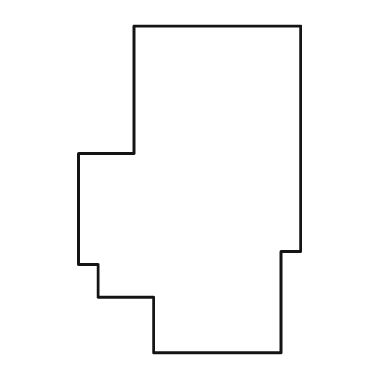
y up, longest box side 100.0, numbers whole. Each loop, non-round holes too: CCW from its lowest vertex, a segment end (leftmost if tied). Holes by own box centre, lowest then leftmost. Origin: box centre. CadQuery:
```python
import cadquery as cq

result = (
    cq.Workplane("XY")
    .moveTo(-11.0, -50.0)
    .lineTo(28.0, -50.0)
    .lineTo(28.0, -19.0)
    .lineTo(34.0, -19.0)
    .lineTo(34.0, 50.0)
    .lineTo(-17.0, 50.0)
    .lineTo(-17.0, 11.0)
    .lineTo(-34.0, 11.0)
    .lineTo(-34.0, -23.0)
    .lineTo(-28.0, -23.0)
    .lineTo(-28.0, -33.0)
    .lineTo(-11.0, -33.0)
    .close()
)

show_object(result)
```